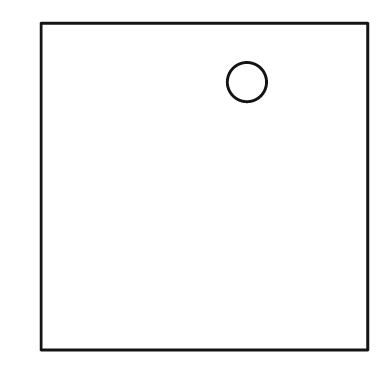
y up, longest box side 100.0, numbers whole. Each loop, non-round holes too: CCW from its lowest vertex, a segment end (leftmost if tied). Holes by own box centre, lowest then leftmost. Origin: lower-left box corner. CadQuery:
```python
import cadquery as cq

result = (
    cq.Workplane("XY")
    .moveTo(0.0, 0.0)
    .lineTo(100.0, 0.0)
    .lineTo(100.0, 100.0)
    .lineTo(0.0, 100.0)
    .close()
    .moveTo(63.0, 82.0)
    .circle(6.0)
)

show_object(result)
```